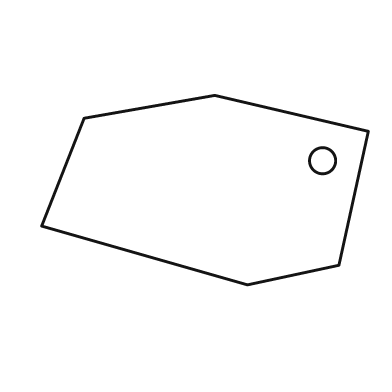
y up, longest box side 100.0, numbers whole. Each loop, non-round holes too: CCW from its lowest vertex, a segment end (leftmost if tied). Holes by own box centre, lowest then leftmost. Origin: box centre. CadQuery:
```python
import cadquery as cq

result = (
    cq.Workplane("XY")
    .moveTo(13.0, -29.0)
    .lineTo(41.0, -23.0)
    .lineTo(50.0, 18.0)
    .lineTo(3.0, 29.0)
    .lineTo(-37.0, 22.0)
    .lineTo(-50.0, -11.0)
    .close()
    .moveTo(36.0, 9.0)
    .circle(4.0)
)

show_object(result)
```